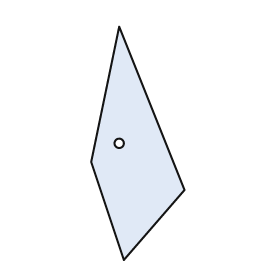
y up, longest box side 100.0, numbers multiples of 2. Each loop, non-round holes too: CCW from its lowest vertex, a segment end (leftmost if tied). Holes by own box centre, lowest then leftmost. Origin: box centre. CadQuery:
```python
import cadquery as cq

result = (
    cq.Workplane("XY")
    .moveTo(-6.0, -50.0)
    .lineTo(20.0, -20.0)
    .lineTo(-8.0, 50.0)
    .lineTo(-20.0, -8.0)
    .close()
    .moveTo(-8.0, 0.0)
    .circle(2.0)
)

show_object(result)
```